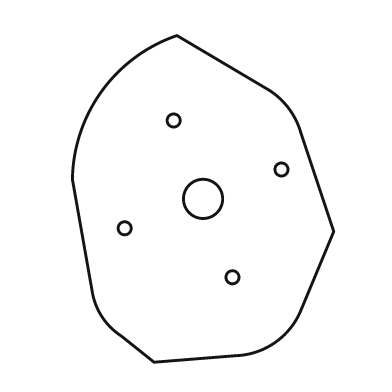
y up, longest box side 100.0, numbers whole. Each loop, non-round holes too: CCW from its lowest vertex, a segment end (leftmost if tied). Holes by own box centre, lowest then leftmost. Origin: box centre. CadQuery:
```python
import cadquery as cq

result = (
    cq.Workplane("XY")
    .moveTo(-15.0, -50.0)
    .lineTo(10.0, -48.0)
    .threePointArc((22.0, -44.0), (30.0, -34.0))
    .lineTo(40.0, -10.0)
    .lineTo(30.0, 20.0)
    .threePointArc((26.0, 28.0), (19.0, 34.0))
    .lineTo(-8.0, 50.0)
    .threePointArc((-31.0, 33.0), (-40.0, 6.0))
    .lineTo(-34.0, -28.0)
    .threePointArc((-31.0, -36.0), (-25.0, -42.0))
    .close()
    .moveTo(9.0, -24.0)
    .circle(2.0)
    .moveTo(-24.0, -9.0)
    .circle(2.0)
    .moveTo(0.0, 0.0)
    .circle(6.0)
    .moveTo(24.0, 9.0)
    .circle(2.0)
    .moveTo(-9.0, 24.0)
    .circle(2.0)
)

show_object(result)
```